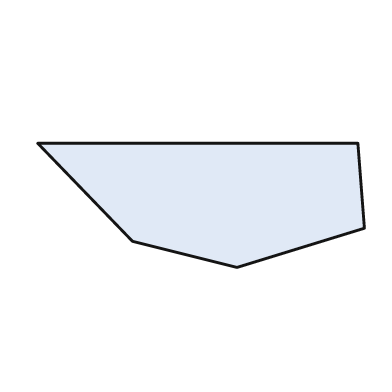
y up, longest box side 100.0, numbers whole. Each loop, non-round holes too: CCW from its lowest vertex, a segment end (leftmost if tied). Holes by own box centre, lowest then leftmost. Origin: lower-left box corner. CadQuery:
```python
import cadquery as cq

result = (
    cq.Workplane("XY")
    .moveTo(61.0, 0.0)
    .lineTo(100.0, 12.0)
    .lineTo(98.0, 38.0)
    .lineTo(0.0, 38.0)
    .lineTo(29.0, 8.0)
    .close()
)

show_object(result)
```